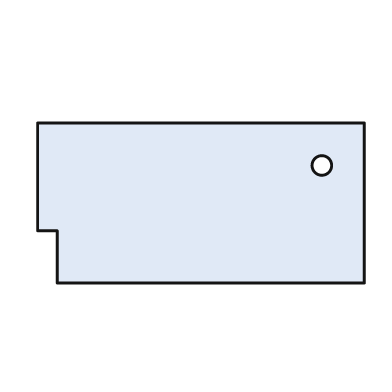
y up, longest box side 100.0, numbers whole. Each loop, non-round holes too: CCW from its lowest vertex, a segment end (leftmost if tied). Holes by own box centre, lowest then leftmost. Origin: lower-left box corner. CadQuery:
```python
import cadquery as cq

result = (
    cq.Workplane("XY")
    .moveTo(6.0, 0.0)
    .lineTo(100.0, 0.0)
    .lineTo(100.0, 49.0)
    .lineTo(0.0, 49.0)
    .lineTo(0.0, 16.0)
    .lineTo(6.0, 16.0)
    .close()
    .moveTo(87.0, 36.0)
    .circle(3.0)
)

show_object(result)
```